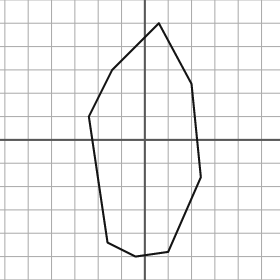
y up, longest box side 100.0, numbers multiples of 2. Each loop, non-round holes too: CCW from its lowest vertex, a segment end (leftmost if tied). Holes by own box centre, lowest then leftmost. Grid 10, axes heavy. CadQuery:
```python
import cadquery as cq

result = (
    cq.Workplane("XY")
    .moveTo(-4.0, -50.0)
    .lineTo(10.0, -48.0)
    .lineTo(24.0, -16.0)
    .lineTo(20.0, 24.0)
    .lineTo(6.0, 50.0)
    .lineTo(-14.0, 30.0)
    .lineTo(-24.0, 10.0)
    .lineTo(-16.0, -44.0)
    .close()
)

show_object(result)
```